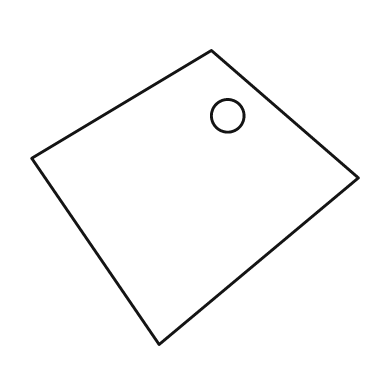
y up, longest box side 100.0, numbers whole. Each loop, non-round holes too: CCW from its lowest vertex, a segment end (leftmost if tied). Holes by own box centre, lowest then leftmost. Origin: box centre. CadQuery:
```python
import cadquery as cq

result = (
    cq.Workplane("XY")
    .moveTo(-11.0, -45.0)
    .lineTo(50.0, 6.0)
    .lineTo(5.0, 45.0)
    .lineTo(-50.0, 12.0)
    .close()
    .moveTo(10.0, 25.0)
    .circle(5.0)
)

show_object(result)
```